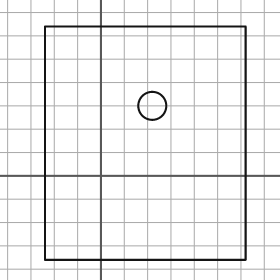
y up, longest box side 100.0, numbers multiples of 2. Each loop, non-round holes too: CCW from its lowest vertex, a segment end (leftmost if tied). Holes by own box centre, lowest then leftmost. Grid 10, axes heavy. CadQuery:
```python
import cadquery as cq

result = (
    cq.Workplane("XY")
    .moveTo(-24.0, -36.0)
    .lineTo(62.0, -36.0)
    .lineTo(62.0, 64.0)
    .lineTo(-24.0, 64.0)
    .close()
    .moveTo(22.0, 30.0)
    .circle(6.0)
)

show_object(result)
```